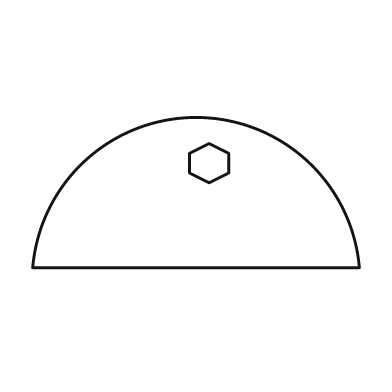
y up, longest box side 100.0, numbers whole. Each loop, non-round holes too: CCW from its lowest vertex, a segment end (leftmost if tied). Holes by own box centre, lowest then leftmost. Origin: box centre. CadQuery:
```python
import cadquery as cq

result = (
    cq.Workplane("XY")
    .moveTo(-50.0, -23.0)
    .lineTo(50.0, -23.0)
    .threePointArc((0.0, 23.0), (-50.0, -23.0))
    .close()
    .moveTo(4.0, 3.0)
    .lineTo(10.0, 6.0)
    .lineTo(10.0, 12.0)
    .lineTo(4.0, 15.0)
    .lineTo(-2.0, 12.0)
    .lineTo(-2.0, 6.0)
    .close()
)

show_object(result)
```